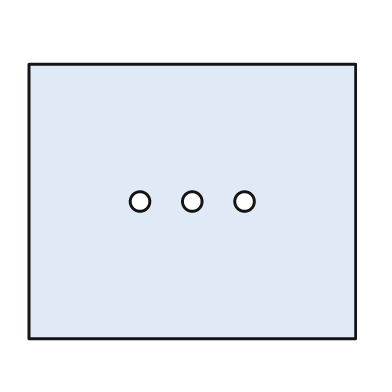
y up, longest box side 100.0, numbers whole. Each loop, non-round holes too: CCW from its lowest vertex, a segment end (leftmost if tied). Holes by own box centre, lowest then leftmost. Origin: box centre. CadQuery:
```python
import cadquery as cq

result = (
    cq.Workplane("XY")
    .moveTo(-50.0, -42.0)
    .lineTo(50.0, -42.0)
    .lineTo(50.0, 42.0)
    .lineTo(-50.0, 42.0)
    .close()
    .moveTo(-16.0, 0.0)
    .circle(3.0)
    .moveTo(0.0, 0.0)
    .circle(3.0)
    .moveTo(16.0, 0.0)
    .circle(3.0)
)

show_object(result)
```